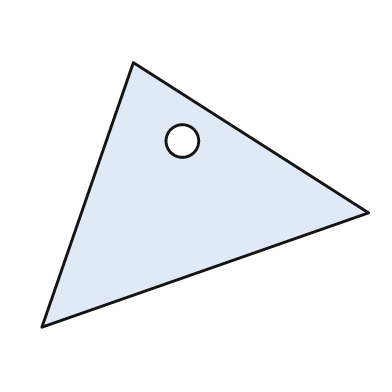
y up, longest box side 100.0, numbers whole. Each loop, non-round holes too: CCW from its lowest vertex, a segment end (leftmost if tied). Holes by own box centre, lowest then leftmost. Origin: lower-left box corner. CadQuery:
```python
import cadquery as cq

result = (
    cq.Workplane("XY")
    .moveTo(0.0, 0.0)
    .lineTo(100.0, 35.0)
    .lineTo(28.0, 81.0)
    .close()
    .moveTo(43.0, 57.0)
    .circle(5.0)
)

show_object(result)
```